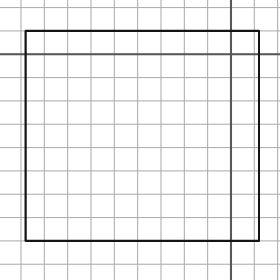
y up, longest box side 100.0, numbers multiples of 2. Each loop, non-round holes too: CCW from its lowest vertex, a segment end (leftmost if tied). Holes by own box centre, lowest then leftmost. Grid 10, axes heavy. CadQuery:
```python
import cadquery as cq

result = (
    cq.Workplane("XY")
    .moveTo(-88.0, -80.0)
    .lineTo(12.0, -80.0)
    .lineTo(12.0, 10.0)
    .lineTo(-88.0, 10.0)
    .close()
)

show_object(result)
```